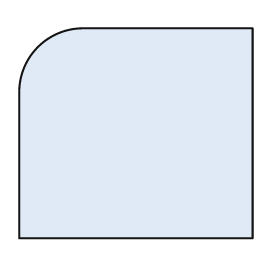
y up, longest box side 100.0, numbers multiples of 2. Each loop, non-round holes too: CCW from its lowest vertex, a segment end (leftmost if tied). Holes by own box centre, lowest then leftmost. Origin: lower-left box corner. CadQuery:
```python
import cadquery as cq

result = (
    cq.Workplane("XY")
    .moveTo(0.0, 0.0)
    .lineTo(100.0, 0.0)
    .lineTo(100.0, 90.0)
    .lineTo(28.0, 90.0)
    .threePointArc((8.0, 82.0), (0.0, 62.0))
    .close()
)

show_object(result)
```